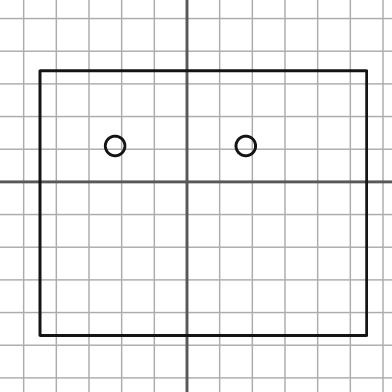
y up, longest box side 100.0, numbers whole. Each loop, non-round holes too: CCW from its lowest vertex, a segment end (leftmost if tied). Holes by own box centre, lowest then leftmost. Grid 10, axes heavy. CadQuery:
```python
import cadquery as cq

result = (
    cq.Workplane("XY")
    .moveTo(-45.0, -47.0)
    .lineTo(55.0, -47.0)
    .lineTo(55.0, 34.0)
    .lineTo(-45.0, 34.0)
    .close()
    .moveTo(-22.0, 11.0)
    .circle(3.0)
    .moveTo(18.0, 11.0)
    .circle(3.0)
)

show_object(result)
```